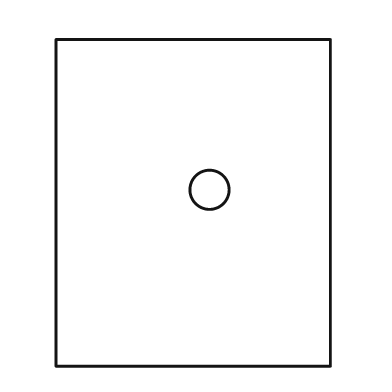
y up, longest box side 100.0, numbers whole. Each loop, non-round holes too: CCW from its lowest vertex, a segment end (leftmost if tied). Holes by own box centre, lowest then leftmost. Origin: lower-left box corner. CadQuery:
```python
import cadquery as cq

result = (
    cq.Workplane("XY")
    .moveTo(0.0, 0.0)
    .lineTo(84.0, 0.0)
    .lineTo(84.0, 100.0)
    .lineTo(0.0, 100.0)
    .close()
    .moveTo(47.0, 54.0)
    .circle(6.0)
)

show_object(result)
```